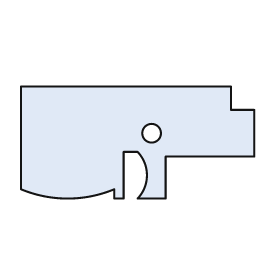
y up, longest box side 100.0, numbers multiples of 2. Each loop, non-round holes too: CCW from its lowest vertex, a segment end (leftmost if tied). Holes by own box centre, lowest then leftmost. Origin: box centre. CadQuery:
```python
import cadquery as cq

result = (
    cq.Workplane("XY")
    .moveTo(-10.0, -24.0)
    .lineTo(-6.0, -24.0)
    .lineTo(-6.0, -4.0)
    .lineTo(0.0, -4.0)
    .threePointArc((4.0, -14.0), (0.0, -24.0))
    .lineTo(12.0, -24.0)
    .lineTo(12.0, -6.0)
    .lineTo(50.0, -6.0)
    .lineTo(50.0, 14.0)
    .lineTo(40.0, 14.0)
    .lineTo(40.0, 24.0)
    .lineTo(-50.0, 24.0)
    .lineTo(-50.0, -20.0)
    .threePointArc((-30.0, -24.0), (-10.0, -20.0))
    .close()
    .moveTo(6.0, 4.0)
    .circle(4.0)
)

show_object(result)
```